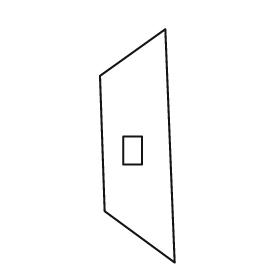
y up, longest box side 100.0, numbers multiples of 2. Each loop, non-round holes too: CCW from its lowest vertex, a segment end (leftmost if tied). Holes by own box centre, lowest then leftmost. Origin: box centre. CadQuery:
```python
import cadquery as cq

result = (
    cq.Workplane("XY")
    .moveTo(16.0, -50.0)
    .lineTo(12.0, 50.0)
    .lineTo(-16.0, 30.0)
    .lineTo(-14.0, -28.0)
    .close()
    .moveTo(-6.0, -8.0)
    .lineTo(2.0, -8.0)
    .lineTo(2.0, 4.0)
    .lineTo(-6.0, 4.0)
    .close()
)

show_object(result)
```